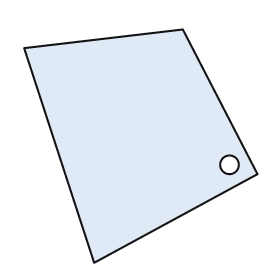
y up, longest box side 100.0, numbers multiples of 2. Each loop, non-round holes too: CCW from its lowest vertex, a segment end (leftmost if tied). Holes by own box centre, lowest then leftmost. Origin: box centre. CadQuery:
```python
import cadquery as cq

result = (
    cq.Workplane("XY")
    .moveTo(-20.0, -50.0)
    .lineTo(50.0, -12.0)
    .lineTo(18.0, 50.0)
    .lineTo(-50.0, 42.0)
    .close()
    .moveTo(38.0, -8.0)
    .circle(4.0)
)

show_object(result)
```